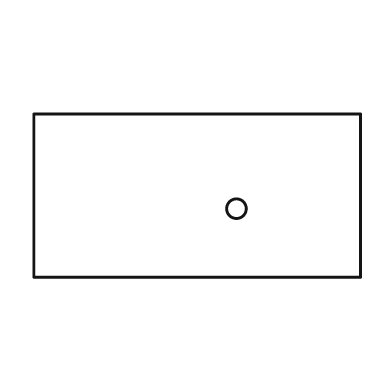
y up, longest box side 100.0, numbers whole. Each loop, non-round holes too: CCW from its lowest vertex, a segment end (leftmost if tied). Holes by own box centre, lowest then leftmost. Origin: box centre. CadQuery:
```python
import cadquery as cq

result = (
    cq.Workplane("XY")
    .moveTo(-50.0, -25.0)
    .lineTo(50.0, -25.0)
    .lineTo(50.0, 25.0)
    .lineTo(-50.0, 25.0)
    .close()
    .moveTo(12.0, -4.0)
    .circle(3.0)
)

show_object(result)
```